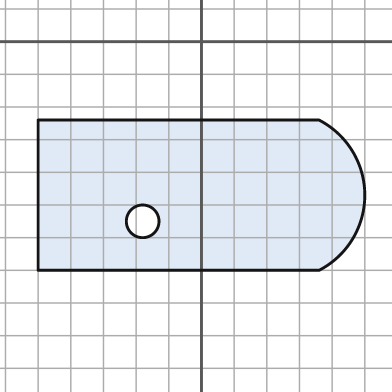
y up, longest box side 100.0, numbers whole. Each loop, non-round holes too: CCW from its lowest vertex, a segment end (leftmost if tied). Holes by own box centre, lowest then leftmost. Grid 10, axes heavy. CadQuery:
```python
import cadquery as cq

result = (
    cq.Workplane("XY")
    .moveTo(-50.0, -70.0)
    .lineTo(36.0, -70.0)
    .threePointArc((50.0, -47.0), (36.0, -24.0))
    .lineTo(-50.0, -24.0)
    .close()
    .moveTo(-18.0, -55.0)
    .circle(5.0)
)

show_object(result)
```